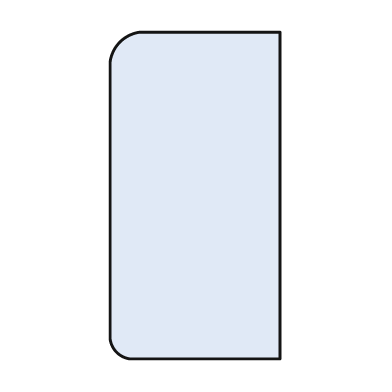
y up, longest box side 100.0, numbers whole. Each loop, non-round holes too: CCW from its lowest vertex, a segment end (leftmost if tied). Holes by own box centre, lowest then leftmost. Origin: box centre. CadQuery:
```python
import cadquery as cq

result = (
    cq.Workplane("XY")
    .moveTo(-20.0, -50.0)
    .lineTo(26.0, -50.0)
    .lineTo(26.0, 50.0)
    .lineTo(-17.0, 50.0)
    .threePointArc((-23.0, 47.0), (-26.0, 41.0))
    .lineTo(-26.0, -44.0)
    .threePointArc((-24.0, -48.0), (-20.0, -50.0))
    .close()
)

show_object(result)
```